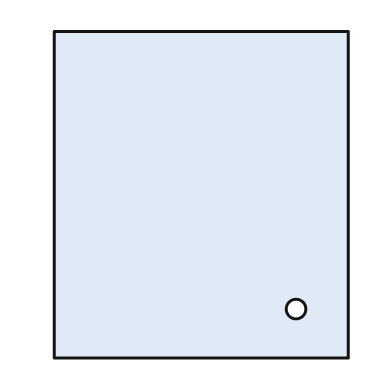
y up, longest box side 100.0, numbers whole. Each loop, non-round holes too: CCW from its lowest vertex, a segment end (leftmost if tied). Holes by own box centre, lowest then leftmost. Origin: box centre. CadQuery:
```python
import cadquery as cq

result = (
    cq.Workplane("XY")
    .moveTo(-45.0, -50.0)
    .lineTo(45.0, -50.0)
    .lineTo(45.0, 50.0)
    .lineTo(-45.0, 50.0)
    .close()
    .moveTo(29.0, -35.0)
    .circle(3.0)
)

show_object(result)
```